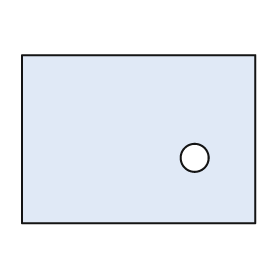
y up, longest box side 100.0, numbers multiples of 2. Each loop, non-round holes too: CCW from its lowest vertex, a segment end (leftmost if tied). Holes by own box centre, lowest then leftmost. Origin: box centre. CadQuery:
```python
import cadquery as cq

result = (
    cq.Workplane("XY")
    .moveTo(-50.0, -36.0)
    .lineTo(50.0, -36.0)
    .lineTo(50.0, 36.0)
    .lineTo(-50.0, 36.0)
    .close()
    .moveTo(24.0, -8.0)
    .circle(6.0)
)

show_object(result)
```